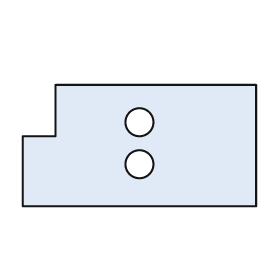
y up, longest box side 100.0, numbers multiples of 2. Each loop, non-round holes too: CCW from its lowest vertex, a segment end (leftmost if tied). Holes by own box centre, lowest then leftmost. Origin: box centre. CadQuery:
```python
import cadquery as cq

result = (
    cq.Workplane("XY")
    .moveTo(-50.0, -26.0)
    .lineTo(50.0, -26.0)
    .lineTo(50.0, 26.0)
    .lineTo(-36.0, 26.0)
    .lineTo(-36.0, 4.0)
    .lineTo(-50.0, 4.0)
    .close()
    .moveTo(0.0, -8.0)
    .circle(6.0)
    .moveTo(0.0, 10.0)
    .circle(6.0)
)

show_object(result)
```